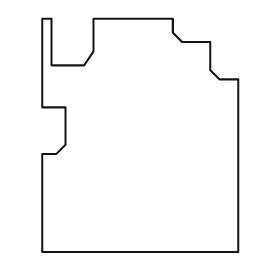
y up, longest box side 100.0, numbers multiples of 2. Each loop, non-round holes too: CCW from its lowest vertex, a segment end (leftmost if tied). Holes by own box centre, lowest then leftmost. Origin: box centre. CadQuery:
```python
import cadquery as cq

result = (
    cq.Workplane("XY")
    .moveTo(-42.0, -50.0)
    .lineTo(42.0, -50.0)
    .lineTo(42.0, 24.0)
    .lineTo(34.0, 24.0)
    .lineTo(30.0, 28.0)
    .lineTo(30.0, 40.0)
    .lineTo(18.0, 40.0)
    .lineTo(14.0, 44.0)
    .lineTo(14.0, 50.0)
    .lineTo(-20.0, 50.0)
    .lineTo(-20.0, 36.0)
    .lineTo(-24.0, 30.0)
    .lineTo(-38.0, 30.0)
    .lineTo(-38.0, 50.0)
    .lineTo(-42.0, 50.0)
    .lineTo(-42.0, 12.0)
    .lineTo(-32.0, 12.0)
    .lineTo(-32.0, -4.0)
    .lineTo(-36.0, -8.0)
    .lineTo(-42.0, -8.0)
    .close()
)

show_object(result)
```